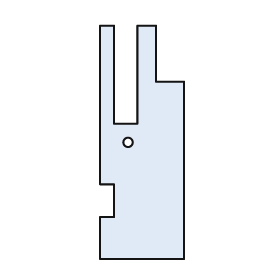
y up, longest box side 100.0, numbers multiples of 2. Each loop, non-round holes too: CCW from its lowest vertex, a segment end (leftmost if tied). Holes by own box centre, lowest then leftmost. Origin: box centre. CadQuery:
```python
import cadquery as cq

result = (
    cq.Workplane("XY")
    .moveTo(-18.0, -50.0)
    .lineTo(18.0, -50.0)
    .lineTo(18.0, 26.0)
    .lineTo(6.0, 26.0)
    .lineTo(6.0, 50.0)
    .lineTo(-2.0, 50.0)
    .lineTo(-2.0, 8.0)
    .lineTo(-12.0, 8.0)
    .lineTo(-12.0, 50.0)
    .lineTo(-18.0, 50.0)
    .lineTo(-18.0, -18.0)
    .lineTo(-12.0, -18.0)
    .lineTo(-12.0, -32.0)
    .lineTo(-18.0, -32.0)
    .close()
    .moveTo(-6.0, 0.0)
    .circle(2.0)
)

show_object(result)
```